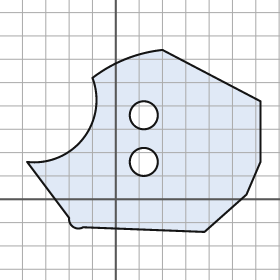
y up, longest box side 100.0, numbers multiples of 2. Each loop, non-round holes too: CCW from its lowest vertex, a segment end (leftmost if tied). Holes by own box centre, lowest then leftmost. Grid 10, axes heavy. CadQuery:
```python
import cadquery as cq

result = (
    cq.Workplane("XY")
    .moveTo(38.0, -14.0)
    .lineTo(56.0, 2.0)
    .lineTo(62.0, 16.0)
    .lineTo(62.0, 42.0)
    .lineTo(20.0, 64.0)
    .threePointArc((4.0, 60.0), (-10.0, 52.0))
    .threePointArc((-14.0, 26.0), (-38.0, 16.0))
    .lineTo(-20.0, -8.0)
    .threePointArc((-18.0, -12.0), (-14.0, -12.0))
    .close()
    .moveTo(12.0, 16.0)
    .circle(6.0)
    .moveTo(12.0, 36.0)
    .circle(6.0)
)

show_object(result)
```